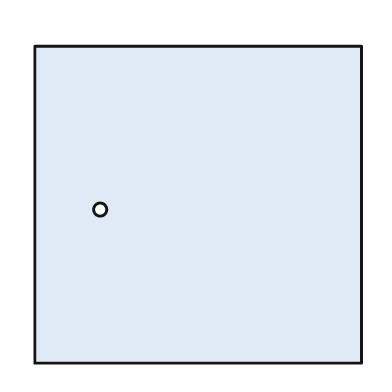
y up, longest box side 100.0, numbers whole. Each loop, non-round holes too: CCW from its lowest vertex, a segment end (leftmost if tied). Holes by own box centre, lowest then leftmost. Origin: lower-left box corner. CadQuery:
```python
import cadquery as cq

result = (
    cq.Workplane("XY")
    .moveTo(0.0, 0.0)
    .lineTo(100.0, 0.0)
    .lineTo(100.0, 97.0)
    .lineTo(0.0, 97.0)
    .close()
    .moveTo(20.0, 47.0)
    .circle(2.0)
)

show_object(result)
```